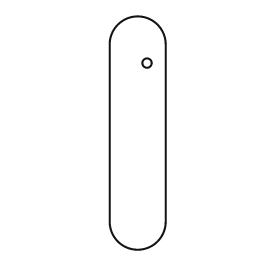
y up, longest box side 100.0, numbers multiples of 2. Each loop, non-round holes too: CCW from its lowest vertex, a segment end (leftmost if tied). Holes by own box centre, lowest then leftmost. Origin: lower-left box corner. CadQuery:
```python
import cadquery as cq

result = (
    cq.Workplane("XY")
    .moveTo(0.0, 12.0)
    .threePointArc((12.0, 0.0), (24.0, 12.0))
    .lineTo(24.0, 88.0)
    .threePointArc((12.0, 100.0), (0.0, 88.0))
    .close()
    .moveTo(16.0, 80.0)
    .circle(2.0)
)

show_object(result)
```